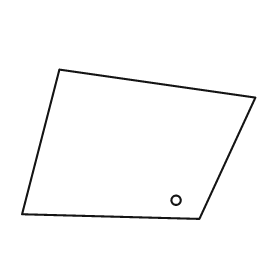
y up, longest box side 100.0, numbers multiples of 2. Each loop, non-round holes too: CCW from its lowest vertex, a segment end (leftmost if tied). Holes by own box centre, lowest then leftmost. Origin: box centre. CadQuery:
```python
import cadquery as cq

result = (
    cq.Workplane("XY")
    .moveTo(26.0, -32.0)
    .lineTo(50.0, 20.0)
    .lineTo(-34.0, 32.0)
    .lineTo(-50.0, -30.0)
    .close()
    .moveTo(16.0, -24.0)
    .circle(2.0)
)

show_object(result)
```